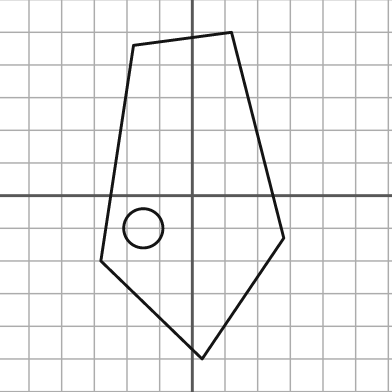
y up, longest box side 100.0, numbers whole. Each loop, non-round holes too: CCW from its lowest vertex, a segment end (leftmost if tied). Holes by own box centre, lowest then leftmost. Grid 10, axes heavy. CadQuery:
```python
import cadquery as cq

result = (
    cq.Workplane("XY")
    .moveTo(3.0, -50.0)
    .lineTo(28.0, -13.0)
    .lineTo(12.0, 50.0)
    .lineTo(-18.0, 46.0)
    .lineTo(-28.0, -20.0)
    .close()
    .moveTo(-15.0, -10.0)
    .circle(6.0)
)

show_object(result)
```